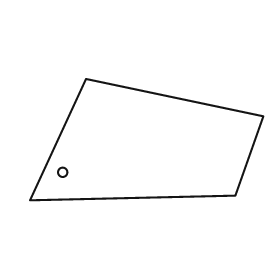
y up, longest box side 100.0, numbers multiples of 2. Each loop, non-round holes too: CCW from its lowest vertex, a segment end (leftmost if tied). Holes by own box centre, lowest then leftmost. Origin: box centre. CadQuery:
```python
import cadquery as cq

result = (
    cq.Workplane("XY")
    .moveTo(-50.0, -26.0)
    .lineTo(38.0, -24.0)
    .lineTo(50.0, 10.0)
    .lineTo(-26.0, 26.0)
    .close()
    .moveTo(-36.0, -14.0)
    .circle(2.0)
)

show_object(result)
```